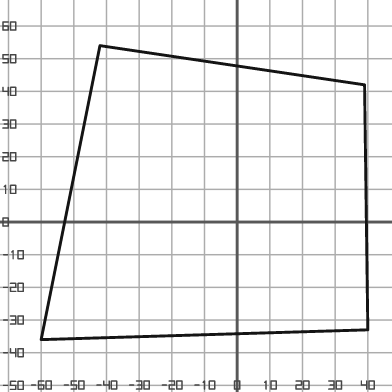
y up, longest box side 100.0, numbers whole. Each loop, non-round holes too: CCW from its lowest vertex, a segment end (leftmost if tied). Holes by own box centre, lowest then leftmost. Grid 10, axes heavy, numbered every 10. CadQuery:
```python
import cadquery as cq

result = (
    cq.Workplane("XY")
    .moveTo(-60.0, -36.0)
    .lineTo(40.0, -33.0)
    .lineTo(39.0, 42.0)
    .lineTo(-42.0, 54.0)
    .close()
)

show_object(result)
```